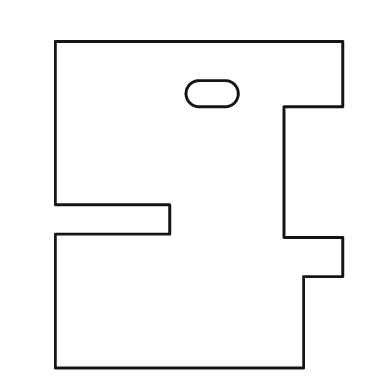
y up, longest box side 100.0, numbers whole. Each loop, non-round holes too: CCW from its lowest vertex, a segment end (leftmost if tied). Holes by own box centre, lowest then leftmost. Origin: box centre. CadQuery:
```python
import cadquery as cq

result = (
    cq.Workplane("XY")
    .moveTo(-44.0, -50.0)
    .lineTo(32.0, -50.0)
    .lineTo(32.0, -22.0)
    .lineTo(44.0, -22.0)
    .lineTo(44.0, -10.0)
    .lineTo(26.0, -10.0)
    .lineTo(26.0, 30.0)
    .lineTo(44.0, 30.0)
    .lineTo(44.0, 50.0)
    .lineTo(-44.0, 50.0)
    .lineTo(-44.0, 0.0)
    .lineTo(-9.0, 0.0)
    .lineTo(-9.0, -9.0)
    .lineTo(-44.0, -9.0)
    .close()
    .moveTo(0.0, 30.0)
    .lineTo(8.0, 30.0)
    .threePointArc((12.0, 34.0), (8.0, 38.0))
    .lineTo(0.0, 38.0)
    .threePointArc((-4.0, 34.0), (0.0, 30.0))
    .close()
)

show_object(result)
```